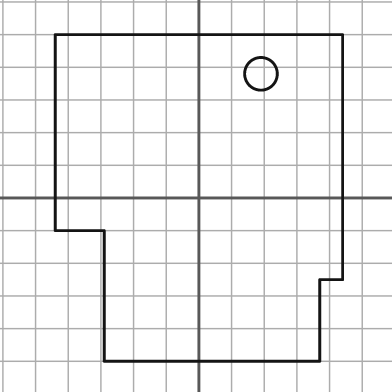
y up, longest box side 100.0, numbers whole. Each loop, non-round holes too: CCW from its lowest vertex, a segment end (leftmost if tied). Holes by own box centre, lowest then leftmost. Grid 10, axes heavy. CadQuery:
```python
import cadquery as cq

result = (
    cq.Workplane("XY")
    .moveTo(-29.0, -50.0)
    .lineTo(37.0, -50.0)
    .lineTo(37.0, -25.0)
    .lineTo(44.0, -25.0)
    .lineTo(44.0, 50.0)
    .lineTo(-44.0, 50.0)
    .lineTo(-44.0, -10.0)
    .lineTo(-29.0, -10.0)
    .close()
    .moveTo(19.0, 38.0)
    .circle(5.0)
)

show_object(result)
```